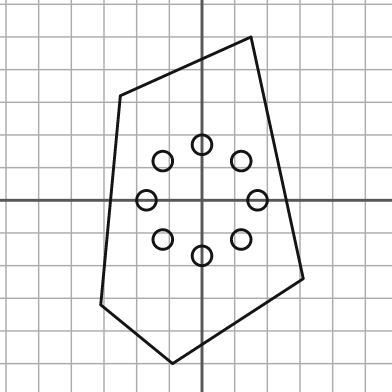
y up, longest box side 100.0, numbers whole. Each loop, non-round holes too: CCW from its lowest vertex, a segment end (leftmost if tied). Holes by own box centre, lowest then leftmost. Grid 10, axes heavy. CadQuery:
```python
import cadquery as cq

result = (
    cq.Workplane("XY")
    .moveTo(-9.0, -50.0)
    .lineTo(31.0, -24.0)
    .lineTo(15.0, 50.0)
    .lineTo(-25.0, 32.0)
    .lineTo(-31.0, -32.0)
    .close()
    .moveTo(0.0, -17.0)
    .circle(3.0)
    .moveTo(-12.0, -12.0)
    .circle(3.0)
    .moveTo(12.0, -12.0)
    .circle(3.0)
    .moveTo(-17.0, 0.0)
    .circle(3.0)
    .moveTo(17.0, 0.0)
    .circle(3.0)
    .moveTo(-12.0, 12.0)
    .circle(3.0)
    .moveTo(12.0, 12.0)
    .circle(3.0)
    .moveTo(0.0, 17.0)
    .circle(3.0)
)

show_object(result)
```